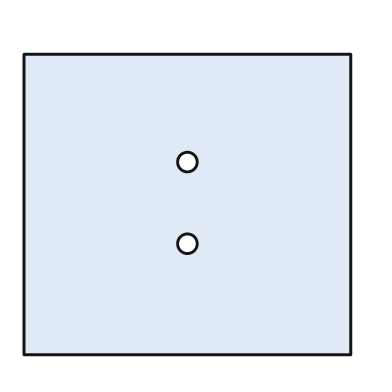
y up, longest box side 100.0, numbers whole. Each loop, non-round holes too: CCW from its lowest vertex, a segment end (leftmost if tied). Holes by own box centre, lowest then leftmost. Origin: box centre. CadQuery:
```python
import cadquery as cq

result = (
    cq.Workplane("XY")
    .moveTo(-50.0, -46.0)
    .lineTo(50.0, -46.0)
    .lineTo(50.0, 46.0)
    .lineTo(-50.0, 46.0)
    .close()
    .moveTo(0.0, -12.0)
    .circle(3.0)
    .moveTo(0.0, 13.0)
    .circle(3.0)
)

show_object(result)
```